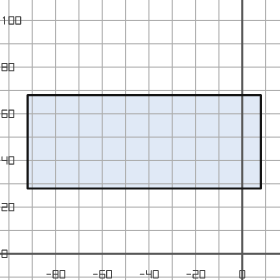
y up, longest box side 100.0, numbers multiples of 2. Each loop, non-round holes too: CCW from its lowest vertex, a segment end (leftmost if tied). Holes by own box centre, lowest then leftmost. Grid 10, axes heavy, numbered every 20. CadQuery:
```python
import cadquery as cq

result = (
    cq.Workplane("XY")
    .moveTo(-92.0, 28.0)
    .lineTo(8.0, 28.0)
    .lineTo(8.0, 68.0)
    .lineTo(-92.0, 68.0)
    .close()
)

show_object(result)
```